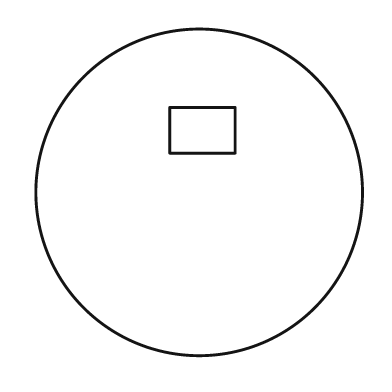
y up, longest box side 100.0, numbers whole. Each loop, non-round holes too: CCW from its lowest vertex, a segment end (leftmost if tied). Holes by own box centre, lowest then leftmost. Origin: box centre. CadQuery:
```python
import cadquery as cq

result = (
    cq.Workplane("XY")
    .moveTo(0.0, 0.0)
    .circle(50.0)
    .moveTo(-9.0, 12.0)
    .lineTo(11.0, 12.0)
    .lineTo(11.0, 26.0)
    .lineTo(-9.0, 26.0)
    .close()
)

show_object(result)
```